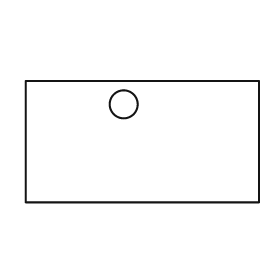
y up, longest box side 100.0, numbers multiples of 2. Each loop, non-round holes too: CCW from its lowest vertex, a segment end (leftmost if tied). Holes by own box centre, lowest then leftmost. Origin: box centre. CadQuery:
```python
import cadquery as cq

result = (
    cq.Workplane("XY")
    .moveTo(-50.0, -26.0)
    .lineTo(50.0, -26.0)
    .lineTo(50.0, 26.0)
    .lineTo(-50.0, 26.0)
    .close()
    .moveTo(-8.0, 16.0)
    .circle(6.0)
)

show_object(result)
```